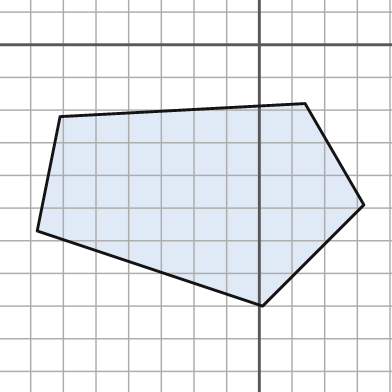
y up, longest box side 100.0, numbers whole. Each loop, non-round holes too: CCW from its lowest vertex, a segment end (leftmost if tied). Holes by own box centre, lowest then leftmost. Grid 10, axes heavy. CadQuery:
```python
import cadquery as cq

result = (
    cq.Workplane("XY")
    .moveTo(1.0, -80.0)
    .lineTo(32.0, -49.0)
    .lineTo(14.0, -18.0)
    .lineTo(-61.0, -22.0)
    .lineTo(-68.0, -57.0)
    .close()
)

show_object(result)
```